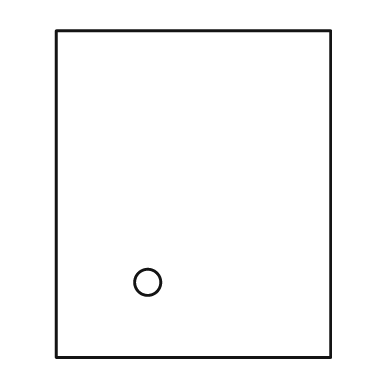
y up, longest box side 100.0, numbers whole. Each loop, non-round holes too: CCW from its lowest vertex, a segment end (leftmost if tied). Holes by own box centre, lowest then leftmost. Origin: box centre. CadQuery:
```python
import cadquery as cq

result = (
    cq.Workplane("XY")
    .moveTo(-42.0, -50.0)
    .lineTo(42.0, -50.0)
    .lineTo(42.0, 50.0)
    .lineTo(-42.0, 50.0)
    .close()
    .moveTo(-14.0, -27.0)
    .circle(4.0)
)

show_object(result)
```